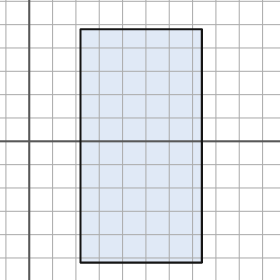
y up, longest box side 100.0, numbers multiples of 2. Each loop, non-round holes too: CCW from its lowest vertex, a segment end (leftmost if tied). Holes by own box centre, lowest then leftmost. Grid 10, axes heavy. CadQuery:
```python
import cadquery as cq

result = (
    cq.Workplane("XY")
    .moveTo(22.0, -52.0)
    .lineTo(74.0, -52.0)
    .lineTo(74.0, 48.0)
    .lineTo(22.0, 48.0)
    .close()
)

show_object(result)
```